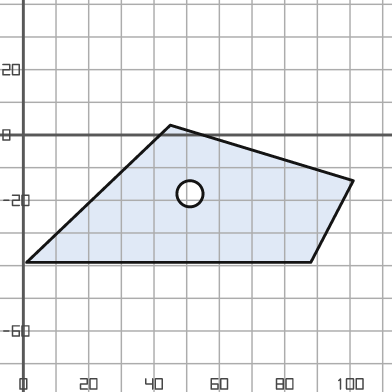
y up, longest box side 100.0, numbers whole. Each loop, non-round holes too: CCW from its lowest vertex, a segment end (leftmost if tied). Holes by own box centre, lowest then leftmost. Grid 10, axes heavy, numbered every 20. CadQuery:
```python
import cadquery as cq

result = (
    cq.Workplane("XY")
    .moveTo(1.0, -39.0)
    .lineTo(88.0, -39.0)
    .lineTo(101.0, -14.0)
    .lineTo(45.0, 3.0)
    .close()
    .moveTo(51.0, -18.0)
    .circle(4.0)
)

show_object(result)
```